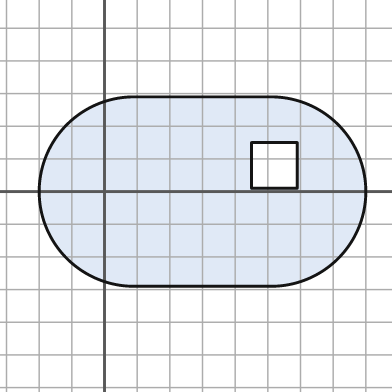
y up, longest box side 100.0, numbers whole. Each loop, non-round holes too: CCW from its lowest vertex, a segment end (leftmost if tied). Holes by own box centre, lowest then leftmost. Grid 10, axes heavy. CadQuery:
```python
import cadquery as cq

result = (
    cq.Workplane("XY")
    .moveTo(9.0, -29.0)
    .lineTo(51.0, -29.0)
    .threePointArc((80.0, 0.0), (51.0, 29.0))
    .lineTo(9.0, 29.0)
    .threePointArc((-20.0, 0.0), (9.0, -29.0))
    .close()
    .moveTo(45.0, 1.0)
    .lineTo(59.0, 1.0)
    .lineTo(59.0, 15.0)
    .lineTo(45.0, 15.0)
    .close()
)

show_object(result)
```